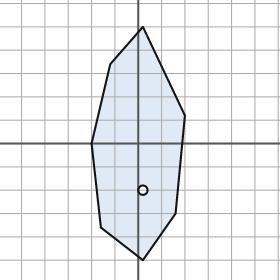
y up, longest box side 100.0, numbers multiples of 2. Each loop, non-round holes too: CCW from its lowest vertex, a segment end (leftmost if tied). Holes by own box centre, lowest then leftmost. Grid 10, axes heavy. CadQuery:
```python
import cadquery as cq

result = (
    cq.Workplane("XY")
    .moveTo(2.0, -50.0)
    .lineTo(16.0, -30.0)
    .lineTo(20.0, 12.0)
    .lineTo(2.0, 50.0)
    .lineTo(-12.0, 34.0)
    .lineTo(-20.0, 0.0)
    .lineTo(-16.0, -36.0)
    .close()
    .moveTo(2.0, -20.0)
    .circle(2.0)
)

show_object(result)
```